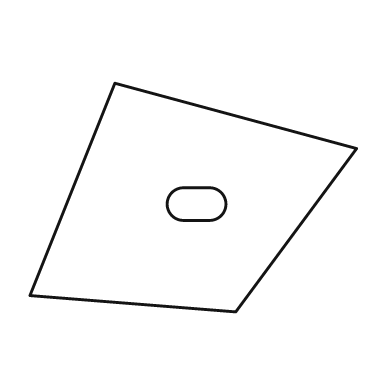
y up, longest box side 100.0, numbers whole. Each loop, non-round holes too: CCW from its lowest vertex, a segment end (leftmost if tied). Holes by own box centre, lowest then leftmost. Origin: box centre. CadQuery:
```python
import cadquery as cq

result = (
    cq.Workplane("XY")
    .moveTo(13.0, -35.0)
    .lineTo(50.0, 15.0)
    .lineTo(-24.0, 35.0)
    .lineTo(-50.0, -30.0)
    .close()
    .moveTo(-3.0, -7.0)
    .lineTo(5.0, -7.0)
    .threePointArc((10.0, -2.0), (5.0, 3.0))
    .lineTo(-3.0, 3.0)
    .threePointArc((-8.0, -2.0), (-3.0, -7.0))
    .close()
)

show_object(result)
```